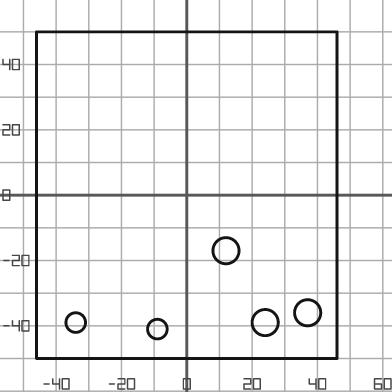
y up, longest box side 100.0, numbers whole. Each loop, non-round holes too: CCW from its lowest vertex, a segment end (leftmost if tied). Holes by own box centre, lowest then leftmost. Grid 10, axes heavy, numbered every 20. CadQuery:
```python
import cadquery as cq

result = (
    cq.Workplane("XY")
    .moveTo(-46.0, -50.0)
    .lineTo(46.0, -50.0)
    .lineTo(46.0, 50.0)
    .lineTo(-46.0, 50.0)
    .close()
    .moveTo(-9.0, -41.0)
    .circle(3.0)
    .moveTo(-34.0, -39.0)
    .circle(3.0)
    .moveTo(24.0, -39.0)
    .circle(4.0)
    .moveTo(37.0, -36.0)
    .circle(4.0)
    .moveTo(12.0, -17.0)
    .circle(4.0)
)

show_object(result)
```